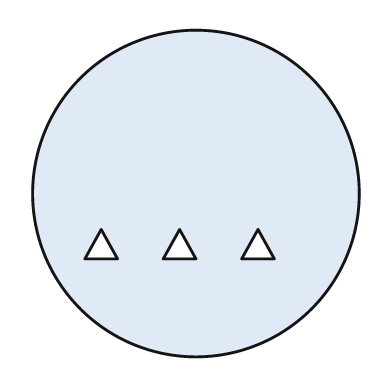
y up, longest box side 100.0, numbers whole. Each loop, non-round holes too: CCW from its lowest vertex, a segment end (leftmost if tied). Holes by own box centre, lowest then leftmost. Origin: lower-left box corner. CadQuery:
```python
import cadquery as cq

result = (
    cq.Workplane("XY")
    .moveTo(50.0, 50.0)
    .circle(50.0)
    .moveTo(16.0, 30.0)
    .lineTo(26.0, 30.0)
    .lineTo(21.0, 39.0)
    .close()
    .moveTo(40.0, 30.0)
    .lineTo(50.0, 30.0)
    .lineTo(45.0, 39.0)
    .close()
    .moveTo(64.0, 30.0)
    .lineTo(74.0, 30.0)
    .lineTo(69.0, 39.0)
    .close()
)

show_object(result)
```